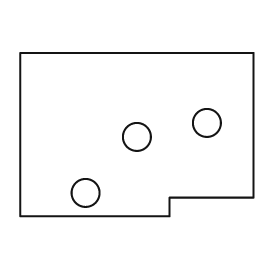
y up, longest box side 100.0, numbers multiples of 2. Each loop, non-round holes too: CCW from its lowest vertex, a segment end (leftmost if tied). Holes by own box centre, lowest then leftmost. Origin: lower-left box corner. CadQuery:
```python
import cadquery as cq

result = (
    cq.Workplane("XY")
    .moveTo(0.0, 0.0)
    .lineTo(64.0, 0.0)
    .lineTo(64.0, 8.0)
    .lineTo(100.0, 8.0)
    .lineTo(100.0, 70.0)
    .lineTo(0.0, 70.0)
    .close()
    .moveTo(28.0, 10.0)
    .circle(6.0)
    .moveTo(50.0, 34.0)
    .circle(6.0)
    .moveTo(80.0, 40.0)
    .circle(6.0)
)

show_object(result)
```